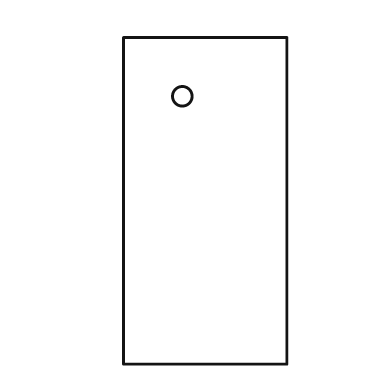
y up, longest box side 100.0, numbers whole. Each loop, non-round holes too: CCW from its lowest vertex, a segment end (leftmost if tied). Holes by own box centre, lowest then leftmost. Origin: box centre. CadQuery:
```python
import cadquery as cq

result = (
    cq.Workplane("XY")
    .moveTo(-25.0, -50.0)
    .lineTo(25.0, -50.0)
    .lineTo(25.0, 50.0)
    .lineTo(-25.0, 50.0)
    .close()
    .moveTo(-7.0, 32.0)
    .circle(3.0)
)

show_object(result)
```